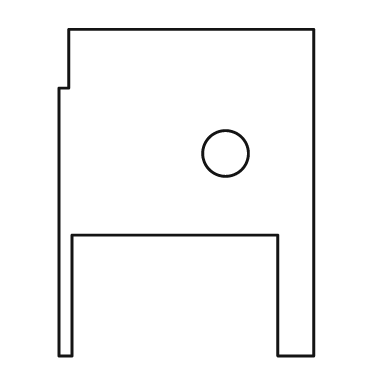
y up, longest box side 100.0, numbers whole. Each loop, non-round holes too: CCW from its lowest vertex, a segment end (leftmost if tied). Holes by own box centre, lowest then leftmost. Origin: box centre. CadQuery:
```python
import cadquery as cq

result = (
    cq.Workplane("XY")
    .moveTo(-39.0, -50.0)
    .lineTo(-35.0, -50.0)
    .lineTo(-35.0, -13.0)
    .lineTo(28.0, -13.0)
    .lineTo(28.0, -50.0)
    .lineTo(39.0, -50.0)
    .lineTo(39.0, 50.0)
    .lineTo(-36.0, 50.0)
    .lineTo(-36.0, 32.0)
    .lineTo(-39.0, 32.0)
    .close()
    .moveTo(12.0, 12.0)
    .circle(7.0)
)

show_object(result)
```